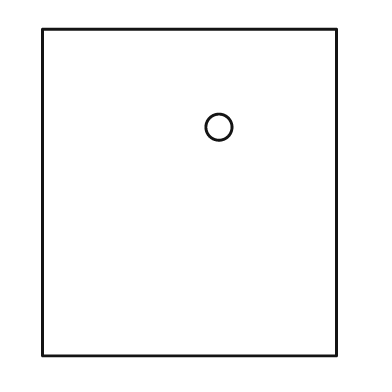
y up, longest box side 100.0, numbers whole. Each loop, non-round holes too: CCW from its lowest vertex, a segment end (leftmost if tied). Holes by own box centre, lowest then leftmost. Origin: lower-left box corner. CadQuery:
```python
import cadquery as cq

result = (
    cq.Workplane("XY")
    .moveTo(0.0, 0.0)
    .lineTo(90.0, 0.0)
    .lineTo(90.0, 100.0)
    .lineTo(0.0, 100.0)
    .close()
    .moveTo(54.0, 70.0)
    .circle(4.0)
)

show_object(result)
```